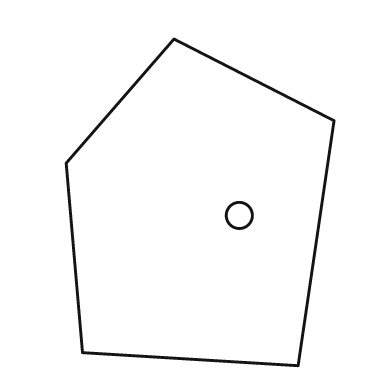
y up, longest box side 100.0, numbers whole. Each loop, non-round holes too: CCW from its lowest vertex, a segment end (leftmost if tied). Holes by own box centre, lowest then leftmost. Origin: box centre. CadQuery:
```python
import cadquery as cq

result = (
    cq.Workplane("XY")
    .moveTo(30.0, -50.0)
    .lineTo(41.0, 25.0)
    .lineTo(-8.0, 50.0)
    .lineTo(-41.0, 12.0)
    .lineTo(-36.0, -46.0)
    .close()
    .moveTo(12.0, -4.0)
    .circle(4.0)
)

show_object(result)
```